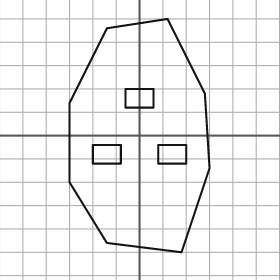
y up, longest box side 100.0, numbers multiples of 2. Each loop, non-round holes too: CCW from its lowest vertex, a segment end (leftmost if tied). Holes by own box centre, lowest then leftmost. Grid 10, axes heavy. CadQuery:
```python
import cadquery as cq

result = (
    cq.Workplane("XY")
    .moveTo(18.0, -50.0)
    .lineTo(30.0, -14.0)
    .lineTo(28.0, 18.0)
    .lineTo(12.0, 50.0)
    .lineTo(-14.0, 46.0)
    .lineTo(-30.0, 14.0)
    .lineTo(-30.0, -20.0)
    .lineTo(-14.0, -46.0)
    .close()
    .moveTo(-20.0, -12.0)
    .lineTo(-8.0, -12.0)
    .lineTo(-8.0, -4.0)
    .lineTo(-20.0, -4.0)
    .close()
    .moveTo(8.0, -12.0)
    .lineTo(20.0, -12.0)
    .lineTo(20.0, -4.0)
    .lineTo(8.0, -4.0)
    .close()
    .moveTo(-6.0, 12.0)
    .lineTo(6.0, 12.0)
    .lineTo(6.0, 20.0)
    .lineTo(-6.0, 20.0)
    .close()
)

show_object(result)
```